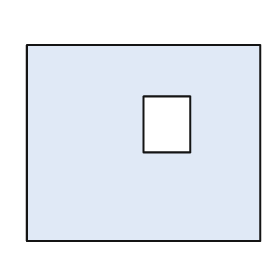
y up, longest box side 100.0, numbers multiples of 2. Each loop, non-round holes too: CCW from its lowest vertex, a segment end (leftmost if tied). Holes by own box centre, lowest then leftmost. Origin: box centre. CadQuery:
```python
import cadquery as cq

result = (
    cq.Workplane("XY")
    .moveTo(-50.0, -42.0)
    .lineTo(50.0, -42.0)
    .lineTo(50.0, 42.0)
    .lineTo(-50.0, 42.0)
    .close()
    .moveTo(0.0, -4.0)
    .lineTo(20.0, -4.0)
    .lineTo(20.0, 20.0)
    .lineTo(0.0, 20.0)
    .close()
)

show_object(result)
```